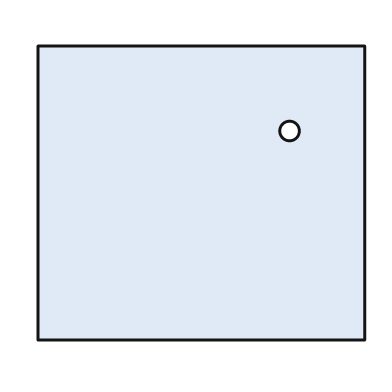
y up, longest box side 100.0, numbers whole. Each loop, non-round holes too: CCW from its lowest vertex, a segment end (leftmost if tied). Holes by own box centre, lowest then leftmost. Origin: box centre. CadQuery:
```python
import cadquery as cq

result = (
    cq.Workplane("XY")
    .moveTo(-50.0, -45.0)
    .lineTo(50.0, -45.0)
    .lineTo(50.0, 45.0)
    .lineTo(-50.0, 45.0)
    .close()
    .moveTo(27.0, 19.0)
    .circle(3.0)
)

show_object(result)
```